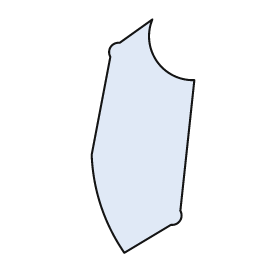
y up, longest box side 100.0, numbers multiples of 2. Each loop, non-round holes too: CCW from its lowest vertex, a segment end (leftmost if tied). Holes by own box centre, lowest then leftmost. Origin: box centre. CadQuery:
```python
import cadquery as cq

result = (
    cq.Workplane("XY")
    .moveTo(-8.0, -50.0)
    .lineTo(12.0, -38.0)
    .threePointArc((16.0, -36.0), (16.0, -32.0))
    .lineTo(22.0, 24.0)
    .threePointArc((6.0, 32.0), (4.0, 50.0))
    .lineTo(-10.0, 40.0)
    .threePointArc((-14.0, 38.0), (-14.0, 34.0))
    .lineTo(-22.0, -8.0)
    .threePointArc((-18.0, -30.0), (-8.0, -50.0))
    .close()
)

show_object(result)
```